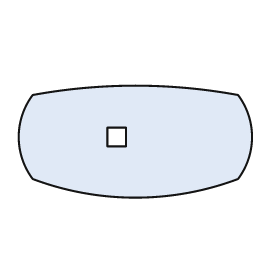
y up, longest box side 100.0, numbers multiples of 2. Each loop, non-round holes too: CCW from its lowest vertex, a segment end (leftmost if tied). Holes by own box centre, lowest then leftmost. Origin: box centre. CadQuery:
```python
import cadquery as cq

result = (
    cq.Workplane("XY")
    .moveTo(-44.0, -16.0)
    .threePointArc((0.0, -24.0), (44.0, -16.0))
    .threePointArc((50.0, 2.0), (44.0, 20.0))
    .threePointArc((0.0, 24.0), (-44.0, 20.0))
    .threePointArc((-50.0, 2.0), (-44.0, -16.0))
    .close()
    .moveTo(-12.0, -2.0)
    .lineTo(-4.0, -2.0)
    .lineTo(-4.0, 6.0)
    .lineTo(-12.0, 6.0)
    .close()
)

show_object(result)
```